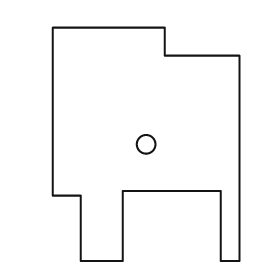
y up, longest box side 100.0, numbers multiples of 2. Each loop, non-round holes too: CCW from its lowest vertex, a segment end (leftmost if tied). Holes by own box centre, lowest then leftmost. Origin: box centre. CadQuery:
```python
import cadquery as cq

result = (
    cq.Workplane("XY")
    .moveTo(-28.0, -50.0)
    .lineTo(-10.0, -50.0)
    .lineTo(-10.0, -20.0)
    .lineTo(32.0, -20.0)
    .lineTo(32.0, -50.0)
    .lineTo(40.0, -50.0)
    .lineTo(40.0, 38.0)
    .lineTo(8.0, 38.0)
    .lineTo(8.0, 50.0)
    .lineTo(-40.0, 50.0)
    .lineTo(-40.0, -22.0)
    .lineTo(-28.0, -22.0)
    .close()
    .moveTo(0.0, 0.0)
    .circle(4.0)
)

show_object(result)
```